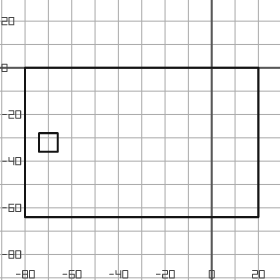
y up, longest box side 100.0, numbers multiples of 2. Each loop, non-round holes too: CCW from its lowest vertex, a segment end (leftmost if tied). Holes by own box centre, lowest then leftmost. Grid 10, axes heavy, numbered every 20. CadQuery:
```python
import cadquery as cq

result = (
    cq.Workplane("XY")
    .moveTo(-80.0, -64.0)
    .lineTo(20.0, -64.0)
    .lineTo(20.0, 0.0)
    .lineTo(-80.0, 0.0)
    .close()
    .moveTo(-74.0, -36.0)
    .lineTo(-66.0, -36.0)
    .lineTo(-66.0, -28.0)
    .lineTo(-74.0, -28.0)
    .close()
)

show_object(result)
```